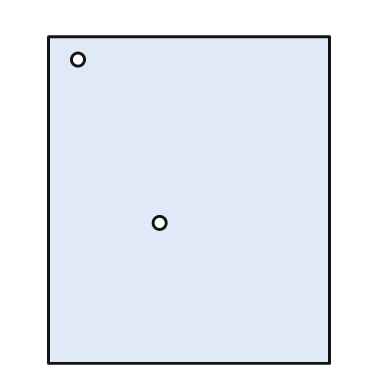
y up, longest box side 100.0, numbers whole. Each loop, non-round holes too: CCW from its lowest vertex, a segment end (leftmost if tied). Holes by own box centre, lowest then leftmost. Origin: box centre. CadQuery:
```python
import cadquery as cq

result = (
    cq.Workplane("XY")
    .moveTo(-43.0, -50.0)
    .lineTo(43.0, -50.0)
    .lineTo(43.0, 50.0)
    .lineTo(-43.0, 50.0)
    .close()
    .moveTo(-9.0, -7.0)
    .circle(2.0)
    .moveTo(-34.0, 43.0)
    .circle(2.0)
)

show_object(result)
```